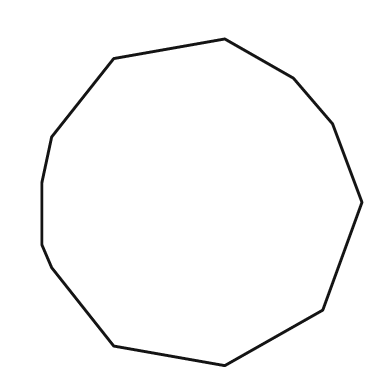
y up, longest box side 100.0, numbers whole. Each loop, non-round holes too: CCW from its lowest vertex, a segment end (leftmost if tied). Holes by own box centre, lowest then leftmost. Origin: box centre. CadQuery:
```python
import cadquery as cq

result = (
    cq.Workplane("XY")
    .moveTo(7.0, -50.0)
    .lineTo(37.0, -33.0)
    .lineTo(49.0, 0.0)
    .lineTo(40.0, 24.0)
    .lineTo(28.0, 38.0)
    .lineTo(7.0, 50.0)
    .lineTo(-27.0, 44.0)
    .lineTo(-46.0, 20.0)
    .lineTo(-49.0, 6.0)
    .lineTo(-49.0, -13.0)
    .lineTo(-46.0, -20.0)
    .lineTo(-27.0, -44.0)
    .close()
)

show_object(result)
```